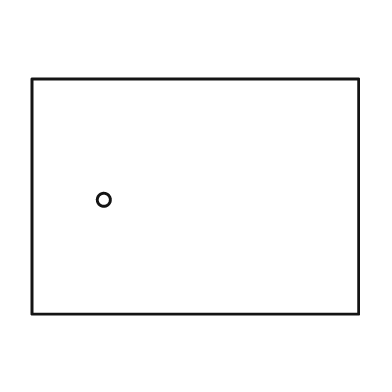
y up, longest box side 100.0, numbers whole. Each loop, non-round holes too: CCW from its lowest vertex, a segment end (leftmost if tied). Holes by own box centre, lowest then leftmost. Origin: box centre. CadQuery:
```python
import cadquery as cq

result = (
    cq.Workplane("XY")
    .moveTo(-50.0, -36.0)
    .lineTo(50.0, -36.0)
    .lineTo(50.0, 36.0)
    .lineTo(-50.0, 36.0)
    .close()
    .moveTo(-28.0, -1.0)
    .circle(2.0)
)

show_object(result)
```